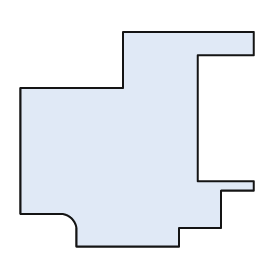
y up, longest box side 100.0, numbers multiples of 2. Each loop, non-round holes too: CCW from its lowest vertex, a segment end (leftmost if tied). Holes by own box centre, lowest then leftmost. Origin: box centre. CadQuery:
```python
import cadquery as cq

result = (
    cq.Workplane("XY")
    .moveTo(-26.0, -46.0)
    .lineTo(18.0, -46.0)
    .lineTo(18.0, -38.0)
    .lineTo(36.0, -38.0)
    .lineTo(36.0, -22.0)
    .lineTo(50.0, -22.0)
    .lineTo(50.0, -18.0)
    .lineTo(26.0, -18.0)
    .lineTo(26.0, 36.0)
    .lineTo(50.0, 36.0)
    .lineTo(50.0, 46.0)
    .lineTo(-6.0, 46.0)
    .lineTo(-6.0, 22.0)
    .lineTo(-50.0, 22.0)
    .lineTo(-50.0, -32.0)
    .lineTo(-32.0, -32.0)
    .threePointArc((-28.0, -34.0), (-26.0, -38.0))
    .close()
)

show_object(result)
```